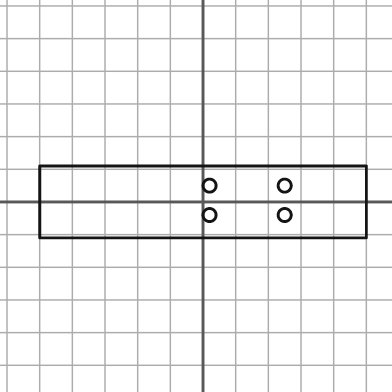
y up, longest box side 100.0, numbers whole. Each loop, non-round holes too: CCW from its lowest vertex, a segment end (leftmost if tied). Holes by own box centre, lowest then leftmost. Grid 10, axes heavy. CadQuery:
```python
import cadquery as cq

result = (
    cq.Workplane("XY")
    .moveTo(-50.0, -11.0)
    .lineTo(50.0, -11.0)
    .lineTo(50.0, 11.0)
    .lineTo(-50.0, 11.0)
    .close()
    .moveTo(2.0, -4.0)
    .circle(2.0)
    .moveTo(25.0, -4.0)
    .circle(2.0)
    .moveTo(2.0, 5.0)
    .circle(2.0)
    .moveTo(25.0, 5.0)
    .circle(2.0)
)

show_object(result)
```